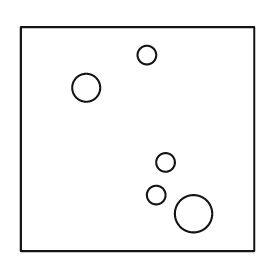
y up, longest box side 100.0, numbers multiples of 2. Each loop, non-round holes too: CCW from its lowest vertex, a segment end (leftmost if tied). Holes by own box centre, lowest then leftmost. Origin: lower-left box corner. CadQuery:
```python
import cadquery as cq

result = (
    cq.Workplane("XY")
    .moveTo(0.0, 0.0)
    .lineTo(100.0, 0.0)
    .lineTo(100.0, 96.0)
    .lineTo(0.0, 96.0)
    .close()
    .moveTo(74.0, 16.0)
    .circle(8.0)
    .moveTo(58.0, 24.0)
    .circle(4.0)
    .moveTo(62.0, 38.0)
    .circle(4.0)
    .moveTo(28.0, 70.0)
    .circle(6.0)
    .moveTo(54.0, 84.0)
    .circle(4.0)
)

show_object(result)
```